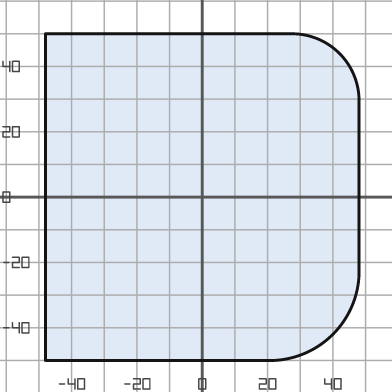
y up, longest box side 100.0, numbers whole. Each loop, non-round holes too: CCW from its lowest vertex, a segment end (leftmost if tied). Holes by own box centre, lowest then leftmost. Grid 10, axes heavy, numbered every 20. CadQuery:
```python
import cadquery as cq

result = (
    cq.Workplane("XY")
    .moveTo(-48.0, -50.0)
    .lineTo(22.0, -50.0)
    .threePointArc((40.0, -42.0), (48.0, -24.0))
    .lineTo(48.0, 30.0)
    .threePointArc((42.0, 44.0), (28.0, 50.0))
    .lineTo(-48.0, 50.0)
    .close()
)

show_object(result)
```